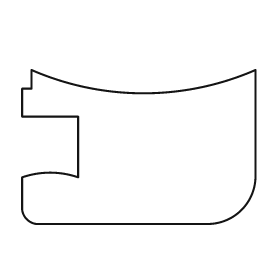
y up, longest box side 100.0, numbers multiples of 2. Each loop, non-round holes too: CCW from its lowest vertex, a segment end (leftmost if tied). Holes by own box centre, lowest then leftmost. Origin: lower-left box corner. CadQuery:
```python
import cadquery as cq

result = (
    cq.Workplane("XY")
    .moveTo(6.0, 0.0)
    .lineTo(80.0, 0.0)
    .threePointArc((94.0, 6.0), (100.0, 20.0))
    .lineTo(100.0, 66.0)
    .threePointArc((52.0, 56.0), (4.0, 66.0))
    .lineTo(4.0, 58.0)
    .lineTo(0.0, 58.0)
    .lineTo(0.0, 46.0)
    .lineTo(24.0, 46.0)
    .lineTo(24.0, 20.0)
    .threePointArc((12.0, 22.0), (0.0, 20.0))
    .lineTo(0.0, 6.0)
    .threePointArc((2.0, 2.0), (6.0, 0.0))
    .close()
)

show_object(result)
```